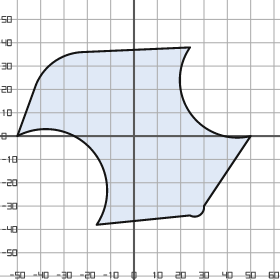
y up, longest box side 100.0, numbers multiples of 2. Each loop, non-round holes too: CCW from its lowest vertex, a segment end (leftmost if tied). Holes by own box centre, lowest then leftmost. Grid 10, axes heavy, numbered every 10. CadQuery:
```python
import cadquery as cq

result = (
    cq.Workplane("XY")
    .moveTo(-16.0, -38.0)
    .lineTo(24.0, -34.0)
    .threePointArc((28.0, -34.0), (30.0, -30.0))
    .lineTo(50.0, 0.0)
    .threePointArc((24.0, 10.0), (24.0, 38.0))
    .lineTo(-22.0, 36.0)
    .threePointArc((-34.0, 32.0), (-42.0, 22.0))
    .lineTo(-50.0, 0.0)
    .threePointArc((-18.0, -6.0), (-16.0, -38.0))
    .close()
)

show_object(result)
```